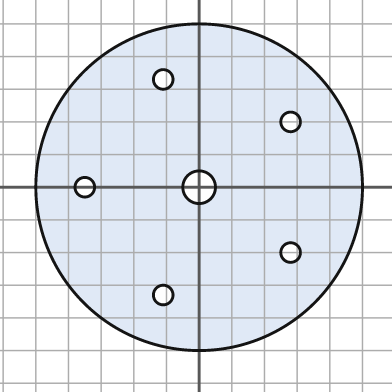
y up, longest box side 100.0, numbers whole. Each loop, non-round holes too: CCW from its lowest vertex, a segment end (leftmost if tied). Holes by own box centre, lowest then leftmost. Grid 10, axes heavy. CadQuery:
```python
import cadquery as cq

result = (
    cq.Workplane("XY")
    .moveTo(0.0, 0.0)
    .circle(50.0)
    .moveTo(-11.0, -33.0)
    .circle(3.0)
    .moveTo(28.0, -20.0)
    .circle(3.0)
    .moveTo(-35.0, 0.0)
    .circle(3.0)
    .moveTo(0.0, 0.0)
    .circle(5.0)
    .moveTo(28.0, 20.0)
    .circle(3.0)
    .moveTo(-11.0, 33.0)
    .circle(3.0)
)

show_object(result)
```